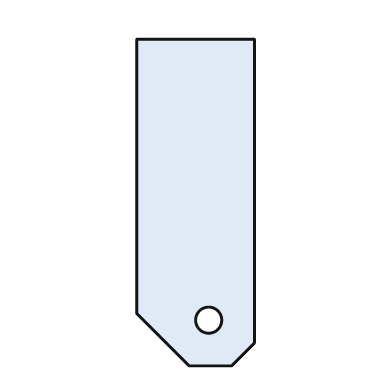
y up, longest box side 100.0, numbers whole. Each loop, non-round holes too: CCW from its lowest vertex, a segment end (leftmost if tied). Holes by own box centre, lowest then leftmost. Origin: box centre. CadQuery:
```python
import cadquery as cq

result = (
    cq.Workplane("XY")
    .moveTo(-2.0, -50.0)
    .lineTo(11.0, -50.0)
    .lineTo(18.0, -43.0)
    .lineTo(18.0, 50.0)
    .lineTo(-18.0, 50.0)
    .lineTo(-18.0, -34.0)
    .close()
    .moveTo(4.0, -36.0)
    .circle(4.0)
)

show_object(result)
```